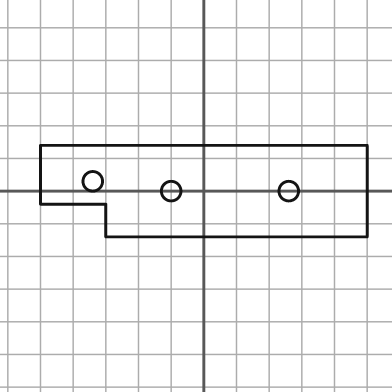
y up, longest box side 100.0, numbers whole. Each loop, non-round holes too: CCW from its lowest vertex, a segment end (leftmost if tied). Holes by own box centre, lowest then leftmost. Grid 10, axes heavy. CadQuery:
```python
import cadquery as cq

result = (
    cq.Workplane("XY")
    .moveTo(-30.0, -14.0)
    .lineTo(50.0, -14.0)
    .lineTo(50.0, 14.0)
    .lineTo(-50.0, 14.0)
    .lineTo(-50.0, -4.0)
    .lineTo(-30.0, -4.0)
    .close()
    .moveTo(-10.0, 0.0)
    .circle(3.0)
    .moveTo(26.0, 0.0)
    .circle(3.0)
    .moveTo(-34.0, 3.0)
    .circle(3.0)
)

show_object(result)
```